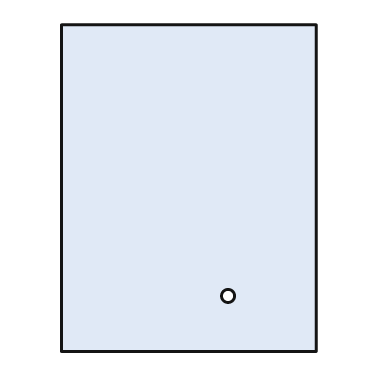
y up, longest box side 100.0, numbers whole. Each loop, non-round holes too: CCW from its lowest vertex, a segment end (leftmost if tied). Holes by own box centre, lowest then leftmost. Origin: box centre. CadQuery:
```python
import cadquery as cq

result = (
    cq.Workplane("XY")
    .moveTo(-39.0, -50.0)
    .lineTo(39.0, -50.0)
    .lineTo(39.0, 50.0)
    .lineTo(-39.0, 50.0)
    .close()
    .moveTo(12.0, -33.0)
    .circle(2.0)
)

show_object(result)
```